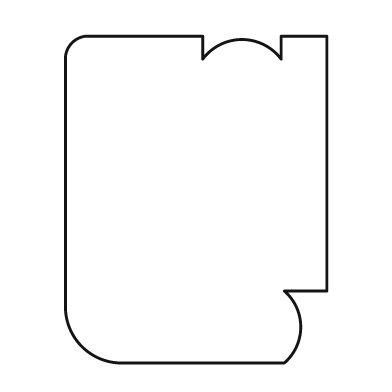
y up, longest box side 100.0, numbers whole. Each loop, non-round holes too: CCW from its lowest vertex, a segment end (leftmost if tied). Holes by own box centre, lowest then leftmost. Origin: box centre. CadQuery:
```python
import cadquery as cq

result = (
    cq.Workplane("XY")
    .moveTo(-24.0, -50.0)
    .lineTo(27.0, -50.0)
    .threePointArc((32.0, -39.0), (27.0, -28.0))
    .lineTo(40.0, -28.0)
    .lineTo(40.0, 50.0)
    .lineTo(26.0, 50.0)
    .lineTo(26.0, 43.0)
    .threePointArc((14.0, 49.0), (2.0, 43.0))
    .lineTo(2.0, 50.0)
    .lineTo(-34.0, 50.0)
    .threePointArc((-38.0, 48.0), (-40.0, 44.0))
    .lineTo(-40.0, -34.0)
    .threePointArc((-35.0, -45.0), (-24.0, -50.0))
    .close()
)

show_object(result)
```